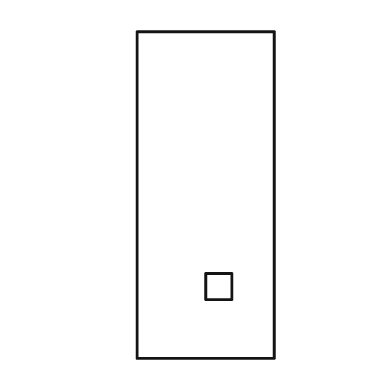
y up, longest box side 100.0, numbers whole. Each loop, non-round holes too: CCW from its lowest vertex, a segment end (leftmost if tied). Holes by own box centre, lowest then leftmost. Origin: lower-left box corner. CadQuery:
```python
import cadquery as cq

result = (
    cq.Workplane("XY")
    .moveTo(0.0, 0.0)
    .lineTo(42.0, 0.0)
    .lineTo(42.0, 100.0)
    .lineTo(0.0, 100.0)
    .close()
    .moveTo(21.0, 18.0)
    .lineTo(29.0, 18.0)
    .lineTo(29.0, 26.0)
    .lineTo(21.0, 26.0)
    .close()
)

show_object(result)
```